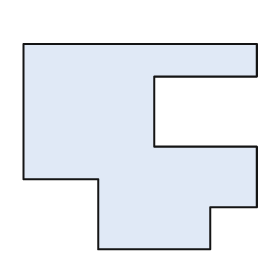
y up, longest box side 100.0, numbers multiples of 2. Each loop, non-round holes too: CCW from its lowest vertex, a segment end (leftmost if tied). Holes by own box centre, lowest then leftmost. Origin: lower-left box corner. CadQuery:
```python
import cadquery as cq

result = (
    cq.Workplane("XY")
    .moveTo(32.0, 0.0)
    .lineTo(80.0, 0.0)
    .lineTo(80.0, 18.0)
    .lineTo(100.0, 18.0)
    .lineTo(100.0, 44.0)
    .lineTo(56.0, 44.0)
    .lineTo(56.0, 74.0)
    .lineTo(100.0, 74.0)
    .lineTo(100.0, 88.0)
    .lineTo(0.0, 88.0)
    .lineTo(0.0, 30.0)
    .lineTo(32.0, 30.0)
    .close()
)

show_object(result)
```